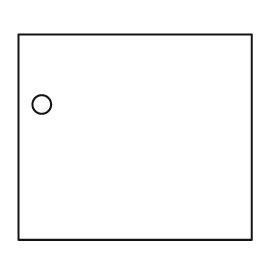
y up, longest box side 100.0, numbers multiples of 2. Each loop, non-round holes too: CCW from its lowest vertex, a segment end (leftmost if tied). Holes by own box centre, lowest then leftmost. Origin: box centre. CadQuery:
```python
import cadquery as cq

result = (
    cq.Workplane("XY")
    .moveTo(-50.0, -44.0)
    .lineTo(50.0, -44.0)
    .lineTo(50.0, 44.0)
    .lineTo(-50.0, 44.0)
    .close()
    .moveTo(-40.0, 14.0)
    .circle(4.0)
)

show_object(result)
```